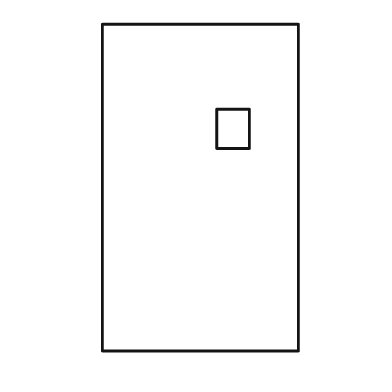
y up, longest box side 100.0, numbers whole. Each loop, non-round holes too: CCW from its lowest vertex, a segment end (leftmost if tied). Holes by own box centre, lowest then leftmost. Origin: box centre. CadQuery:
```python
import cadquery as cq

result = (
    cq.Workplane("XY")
    .moveTo(-30.0, -50.0)
    .lineTo(30.0, -50.0)
    .lineTo(30.0, 50.0)
    .lineTo(-30.0, 50.0)
    .close()
    .moveTo(5.0, 12.0)
    .lineTo(15.0, 12.0)
    .lineTo(15.0, 24.0)
    .lineTo(5.0, 24.0)
    .close()
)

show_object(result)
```